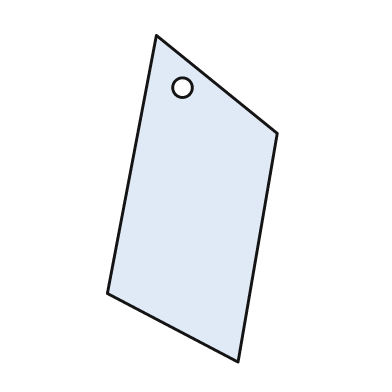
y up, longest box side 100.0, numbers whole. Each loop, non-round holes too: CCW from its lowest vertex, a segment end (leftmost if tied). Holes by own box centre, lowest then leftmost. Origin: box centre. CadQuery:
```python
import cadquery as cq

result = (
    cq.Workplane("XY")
    .moveTo(14.0, -50.0)
    .lineTo(26.0, 20.0)
    .lineTo(-11.0, 50.0)
    .lineTo(-26.0, -29.0)
    .close()
    .moveTo(-3.0, 34.0)
    .circle(3.0)
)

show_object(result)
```